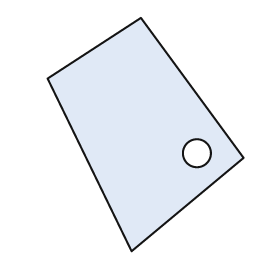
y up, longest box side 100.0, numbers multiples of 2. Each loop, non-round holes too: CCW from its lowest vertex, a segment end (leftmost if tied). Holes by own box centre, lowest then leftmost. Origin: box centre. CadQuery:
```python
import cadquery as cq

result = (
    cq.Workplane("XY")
    .moveTo(-6.0, -50.0)
    .lineTo(42.0, -10.0)
    .lineTo(-2.0, 50.0)
    .lineTo(-42.0, 24.0)
    .close()
    .moveTo(22.0, -8.0)
    .circle(6.0)
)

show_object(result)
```